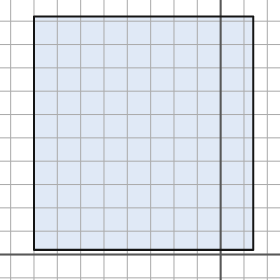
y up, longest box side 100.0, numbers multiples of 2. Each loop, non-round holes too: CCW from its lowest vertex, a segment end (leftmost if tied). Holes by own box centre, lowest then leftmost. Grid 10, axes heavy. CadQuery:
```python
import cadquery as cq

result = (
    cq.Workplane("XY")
    .moveTo(-80.0, 2.0)
    .lineTo(14.0, 2.0)
    .lineTo(14.0, 102.0)
    .lineTo(-80.0, 102.0)
    .close()
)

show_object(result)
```